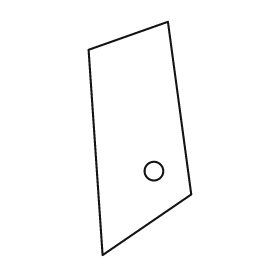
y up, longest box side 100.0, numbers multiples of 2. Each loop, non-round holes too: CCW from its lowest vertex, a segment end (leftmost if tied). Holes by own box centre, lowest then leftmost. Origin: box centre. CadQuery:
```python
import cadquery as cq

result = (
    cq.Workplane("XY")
    .moveTo(-16.0, -50.0)
    .lineTo(22.0, -24.0)
    .lineTo(12.0, 50.0)
    .lineTo(-22.0, 38.0)
    .close()
    .moveTo(6.0, -14.0)
    .circle(4.0)
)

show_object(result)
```